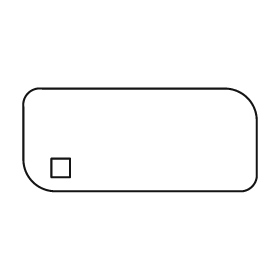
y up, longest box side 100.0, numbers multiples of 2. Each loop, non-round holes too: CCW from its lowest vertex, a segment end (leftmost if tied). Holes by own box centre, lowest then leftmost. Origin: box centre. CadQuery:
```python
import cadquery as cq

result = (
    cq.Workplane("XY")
    .moveTo(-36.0, -22.0)
    .lineTo(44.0, -22.0)
    .threePointArc((48.0, -20.0), (50.0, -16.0))
    .lineTo(50.0, 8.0)
    .threePointArc((46.0, 18.0), (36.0, 22.0))
    .lineTo(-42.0, 22.0)
    .threePointArc((-48.0, 20.0), (-50.0, 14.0))
    .lineTo(-50.0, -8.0)
    .threePointArc((-46.0, -18.0), (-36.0, -22.0))
    .close()
    .moveTo(-38.0, -16.0)
    .lineTo(-30.0, -16.0)
    .lineTo(-30.0, -8.0)
    .lineTo(-38.0, -8.0)
    .close()
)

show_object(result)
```